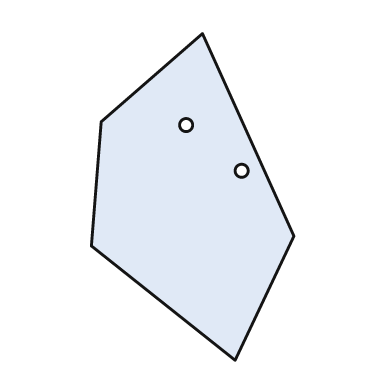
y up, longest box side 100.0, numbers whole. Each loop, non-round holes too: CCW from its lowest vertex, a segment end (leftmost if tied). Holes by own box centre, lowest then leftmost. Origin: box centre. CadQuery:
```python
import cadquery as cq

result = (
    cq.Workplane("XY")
    .moveTo(13.0, -50.0)
    .lineTo(31.0, -12.0)
    .lineTo(3.0, 50.0)
    .lineTo(-28.0, 23.0)
    .lineTo(-31.0, -15.0)
    .close()
    .moveTo(15.0, 8.0)
    .circle(2.0)
    .moveTo(-2.0, 22.0)
    .circle(2.0)
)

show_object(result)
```